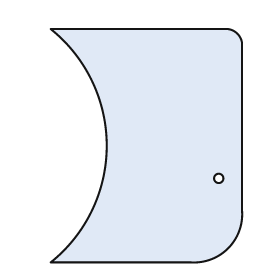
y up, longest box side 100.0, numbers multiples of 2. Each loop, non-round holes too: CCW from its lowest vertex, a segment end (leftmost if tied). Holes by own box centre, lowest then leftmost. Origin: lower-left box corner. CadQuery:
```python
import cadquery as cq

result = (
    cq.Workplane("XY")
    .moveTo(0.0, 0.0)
    .lineTo(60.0, 0.0)
    .threePointArc((76.0, 6.0), (82.0, 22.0))
    .lineTo(82.0, 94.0)
    .threePointArc((80.0, 98.0), (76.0, 100.0))
    .lineTo(0.0, 100.0)
    .threePointArc((24.0, 50.0), (0.0, 0.0))
    .close()
    .moveTo(72.0, 36.0)
    .circle(2.0)
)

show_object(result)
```